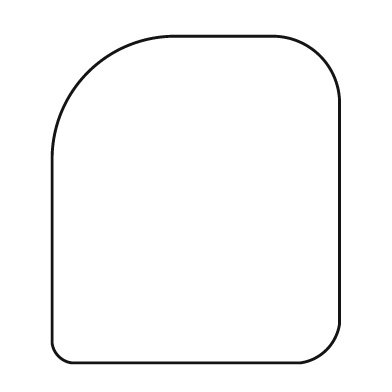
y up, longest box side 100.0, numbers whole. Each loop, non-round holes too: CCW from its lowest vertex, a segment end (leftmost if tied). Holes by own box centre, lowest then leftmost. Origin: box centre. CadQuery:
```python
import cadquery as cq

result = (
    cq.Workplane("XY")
    .moveTo(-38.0, -50.0)
    .lineTo(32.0, -50.0)
    .threePointArc((40.0, -46.0), (44.0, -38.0))
    .lineTo(44.0, 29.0)
    .threePointArc((38.0, 44.0), (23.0, 50.0))
    .lineTo(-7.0, 50.0)
    .threePointArc((-33.0, 39.0), (-44.0, 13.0))
    .lineTo(-44.0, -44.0)
    .threePointArc((-42.0, -48.0), (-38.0, -50.0))
    .close()
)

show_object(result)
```